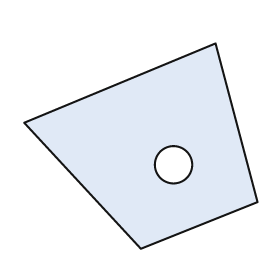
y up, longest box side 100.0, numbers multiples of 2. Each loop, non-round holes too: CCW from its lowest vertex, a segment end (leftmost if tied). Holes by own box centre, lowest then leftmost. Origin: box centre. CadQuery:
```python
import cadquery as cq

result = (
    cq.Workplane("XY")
    .moveTo(0.0, -44.0)
    .lineTo(50.0, -24.0)
    .lineTo(32.0, 44.0)
    .lineTo(-50.0, 10.0)
    .close()
    .moveTo(14.0, -8.0)
    .circle(8.0)
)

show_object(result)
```